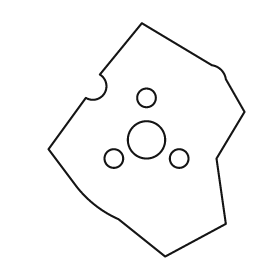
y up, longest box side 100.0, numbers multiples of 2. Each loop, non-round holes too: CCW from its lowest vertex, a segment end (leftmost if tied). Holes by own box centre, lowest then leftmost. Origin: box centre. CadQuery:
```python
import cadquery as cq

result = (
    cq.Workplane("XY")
    .moveTo(8.0, -50.0)
    .lineTo(34.0, -36.0)
    .lineTo(30.0, -8.0)
    .lineTo(42.0, 12.0)
    .lineTo(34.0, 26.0)
    .threePointArc((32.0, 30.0), (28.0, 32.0))
    .lineTo(-2.0, 50.0)
    .lineTo(-20.0, 28.0)
    .threePointArc((-18.0, 20.0), (-26.0, 18.0))
    .lineTo(-42.0, -4.0)
    .lineTo(-30.0, -20.0)
    .threePointArc((-22.0, -28.0), (-12.0, -34.0))
    .close()
    .moveTo(-14.0, -8.0)
    .circle(4.0)
    .moveTo(14.0, -8.0)
    .circle(4.0)
    .moveTo(0.0, 0.0)
    .circle(8.0)
    .moveTo(0.0, 18.0)
    .circle(4.0)
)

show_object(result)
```